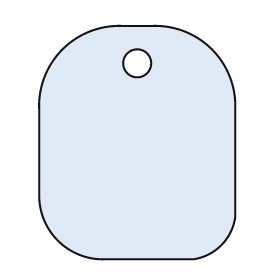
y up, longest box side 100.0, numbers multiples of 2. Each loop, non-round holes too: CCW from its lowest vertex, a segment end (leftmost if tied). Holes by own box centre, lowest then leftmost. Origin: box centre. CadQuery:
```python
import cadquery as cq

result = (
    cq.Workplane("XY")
    .moveTo(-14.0, -50.0)
    .lineTo(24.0, -50.0)
    .threePointArc((36.0, -44.0), (42.0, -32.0))
    .lineTo(42.0, 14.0)
    .threePointArc((32.0, 40.0), (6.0, 50.0))
    .lineTo(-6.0, 50.0)
    .threePointArc((-32.0, 40.0), (-42.0, 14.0))
    .lineTo(-42.0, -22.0)
    .threePointArc((-34.0, -42.0), (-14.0, -50.0))
    .close()
    .moveTo(0.0, 34.0)
    .circle(6.0)
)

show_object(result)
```